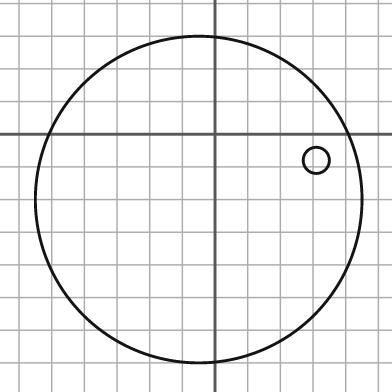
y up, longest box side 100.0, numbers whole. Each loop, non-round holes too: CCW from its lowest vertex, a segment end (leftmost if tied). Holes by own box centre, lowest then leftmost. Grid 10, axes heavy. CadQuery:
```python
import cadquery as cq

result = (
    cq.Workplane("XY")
    .moveTo(-5.0, -20.0)
    .circle(50.0)
    .moveTo(31.0, -8.0)
    .circle(4.0)
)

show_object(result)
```